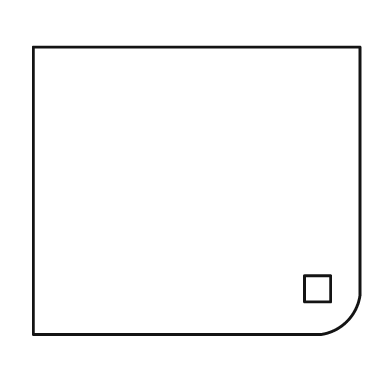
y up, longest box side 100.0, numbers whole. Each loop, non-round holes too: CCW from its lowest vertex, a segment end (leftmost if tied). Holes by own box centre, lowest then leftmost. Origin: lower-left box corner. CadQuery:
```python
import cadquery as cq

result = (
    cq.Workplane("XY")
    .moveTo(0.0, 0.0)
    .lineTo(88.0, 0.0)
    .threePointArc((96.0, 4.0), (100.0, 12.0))
    .lineTo(100.0, 88.0)
    .lineTo(0.0, 88.0)
    .close()
    .moveTo(83.0, 10.0)
    .lineTo(91.0, 10.0)
    .lineTo(91.0, 18.0)
    .lineTo(83.0, 18.0)
    .close()
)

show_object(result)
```